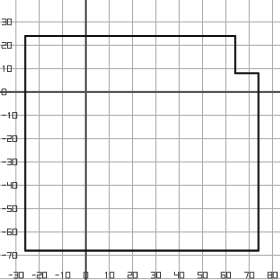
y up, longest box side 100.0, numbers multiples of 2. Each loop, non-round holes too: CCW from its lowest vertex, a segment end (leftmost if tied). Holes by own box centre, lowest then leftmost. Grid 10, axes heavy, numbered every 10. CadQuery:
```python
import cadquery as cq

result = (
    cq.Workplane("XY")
    .moveTo(-26.0, -68.0)
    .lineTo(74.0, -68.0)
    .lineTo(74.0, 8.0)
    .lineTo(64.0, 8.0)
    .lineTo(64.0, 24.0)
    .lineTo(-26.0, 24.0)
    .close()
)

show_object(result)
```